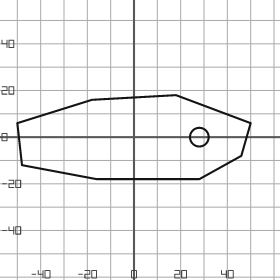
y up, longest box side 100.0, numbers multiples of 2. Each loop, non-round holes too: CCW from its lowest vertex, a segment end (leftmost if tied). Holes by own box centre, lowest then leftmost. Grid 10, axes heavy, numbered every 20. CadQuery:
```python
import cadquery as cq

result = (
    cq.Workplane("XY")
    .moveTo(-16.0, -18.0)
    .lineTo(28.0, -18.0)
    .lineTo(46.0, -8.0)
    .lineTo(50.0, 6.0)
    .lineTo(18.0, 18.0)
    .lineTo(-18.0, 16.0)
    .lineTo(-50.0, 6.0)
    .lineTo(-48.0, -12.0)
    .close()
    .moveTo(28.0, 0.0)
    .circle(4.0)
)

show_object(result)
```